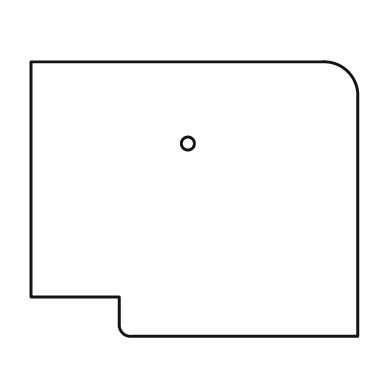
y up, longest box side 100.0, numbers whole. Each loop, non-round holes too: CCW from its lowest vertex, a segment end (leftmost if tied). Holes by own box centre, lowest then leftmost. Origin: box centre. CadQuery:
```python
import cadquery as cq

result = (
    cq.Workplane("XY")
    .moveTo(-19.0, -42.0)
    .lineTo(50.0, -42.0)
    .lineTo(50.0, 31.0)
    .threePointArc((47.0, 39.0), (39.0, 42.0))
    .lineTo(-50.0, 42.0)
    .lineTo(-50.0, -30.0)
    .lineTo(-23.0, -30.0)
    .lineTo(-23.0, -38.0)
    .threePointArc((-22.0, -41.0), (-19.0, -42.0))
    .close()
    .moveTo(-2.0, 17.0)
    .circle(2.0)
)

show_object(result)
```